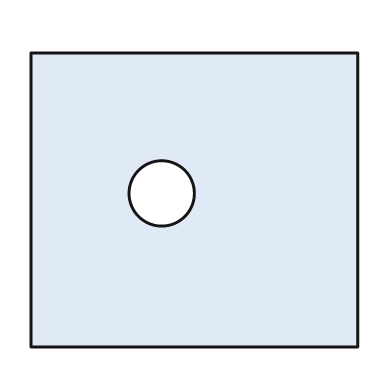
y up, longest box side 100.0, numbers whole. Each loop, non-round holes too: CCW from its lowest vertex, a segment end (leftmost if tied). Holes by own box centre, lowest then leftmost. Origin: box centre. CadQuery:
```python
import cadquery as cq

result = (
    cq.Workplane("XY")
    .moveTo(-50.0, -45.0)
    .lineTo(50.0, -45.0)
    .lineTo(50.0, 45.0)
    .lineTo(-50.0, 45.0)
    .close()
    .moveTo(-10.0, 2.0)
    .circle(10.0)
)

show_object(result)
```